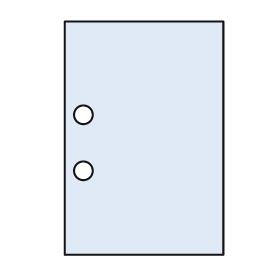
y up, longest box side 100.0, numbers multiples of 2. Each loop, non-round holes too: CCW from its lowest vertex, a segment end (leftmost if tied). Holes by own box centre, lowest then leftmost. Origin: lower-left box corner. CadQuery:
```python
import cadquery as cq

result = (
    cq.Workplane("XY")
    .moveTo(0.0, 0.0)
    .lineTo(68.0, 0.0)
    .lineTo(68.0, 100.0)
    .lineTo(0.0, 100.0)
    .close()
    .moveTo(8.0, 36.0)
    .circle(4.0)
    .moveTo(8.0, 60.0)
    .circle(4.0)
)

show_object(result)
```